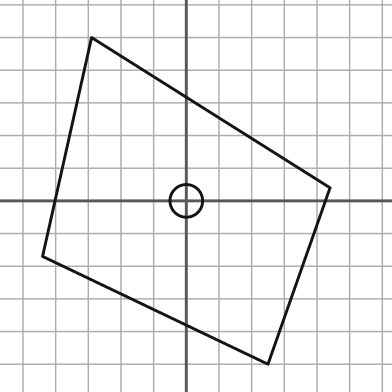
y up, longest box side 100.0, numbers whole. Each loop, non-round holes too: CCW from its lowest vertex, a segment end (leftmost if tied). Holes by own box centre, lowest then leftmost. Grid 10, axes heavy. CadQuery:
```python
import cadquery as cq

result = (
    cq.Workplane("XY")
    .moveTo(25.0, -50.0)
    .lineTo(44.0, 4.0)
    .lineTo(-29.0, 50.0)
    .lineTo(-44.0, -17.0)
    .close()
    .moveTo(0.0, 0.0)
    .circle(5.0)
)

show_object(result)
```